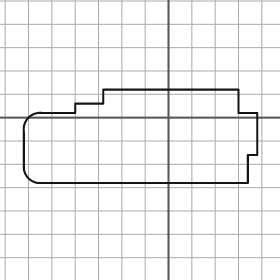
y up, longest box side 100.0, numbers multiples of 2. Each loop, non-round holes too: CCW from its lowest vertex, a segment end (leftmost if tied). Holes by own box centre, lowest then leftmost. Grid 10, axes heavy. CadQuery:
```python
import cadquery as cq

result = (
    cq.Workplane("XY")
    .moveTo(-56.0, -28.0)
    .lineTo(34.0, -28.0)
    .lineTo(34.0, -16.0)
    .lineTo(38.0, -16.0)
    .lineTo(38.0, 2.0)
    .lineTo(30.0, 2.0)
    .lineTo(30.0, 12.0)
    .lineTo(-28.0, 12.0)
    .lineTo(-28.0, 6.0)
    .lineTo(-40.0, 6.0)
    .lineTo(-40.0, 2.0)
    .lineTo(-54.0, 2.0)
    .threePointArc((-60.0, 0.0), (-62.0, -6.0))
    .lineTo(-62.0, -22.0)
    .threePointArc((-60.0, -26.0), (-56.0, -28.0))
    .close()
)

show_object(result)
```